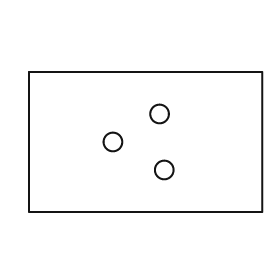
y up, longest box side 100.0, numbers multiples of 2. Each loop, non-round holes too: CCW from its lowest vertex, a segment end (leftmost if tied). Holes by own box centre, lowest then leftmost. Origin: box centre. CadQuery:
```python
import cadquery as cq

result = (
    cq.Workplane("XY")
    .moveTo(-50.0, -30.0)
    .lineTo(50.0, -30.0)
    .lineTo(50.0, 30.0)
    .lineTo(-50.0, 30.0)
    .close()
    .moveTo(8.0, -12.0)
    .circle(4.0)
    .moveTo(-14.0, 0.0)
    .circle(4.0)
    .moveTo(6.0, 12.0)
    .circle(4.0)
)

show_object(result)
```